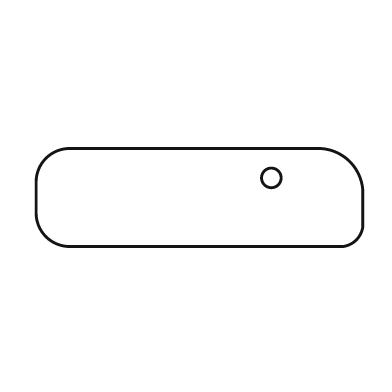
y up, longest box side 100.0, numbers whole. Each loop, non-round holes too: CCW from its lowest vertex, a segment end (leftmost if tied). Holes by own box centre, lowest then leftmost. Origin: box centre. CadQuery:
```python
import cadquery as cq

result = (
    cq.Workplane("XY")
    .moveTo(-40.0, -15.0)
    .lineTo(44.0, -15.0)
    .threePointArc((48.0, -13.0), (50.0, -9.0))
    .lineTo(50.0, 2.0)
    .threePointArc((46.0, 11.0), (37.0, 15.0))
    .lineTo(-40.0, 15.0)
    .threePointArc((-47.0, 12.0), (-50.0, 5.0))
    .lineTo(-50.0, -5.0)
    .threePointArc((-47.0, -12.0), (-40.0, -15.0))
    .close()
    .moveTo(22.0, 6.0)
    .circle(3.0)
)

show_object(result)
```